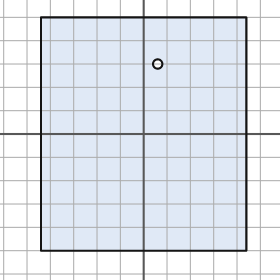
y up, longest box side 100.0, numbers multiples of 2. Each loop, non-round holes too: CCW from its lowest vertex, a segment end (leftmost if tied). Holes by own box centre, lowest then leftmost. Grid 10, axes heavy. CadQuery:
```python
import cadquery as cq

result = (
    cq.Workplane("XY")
    .moveTo(-44.0, -50.0)
    .lineTo(44.0, -50.0)
    .lineTo(44.0, 50.0)
    .lineTo(-44.0, 50.0)
    .close()
    .moveTo(6.0, 30.0)
    .circle(2.0)
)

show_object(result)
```